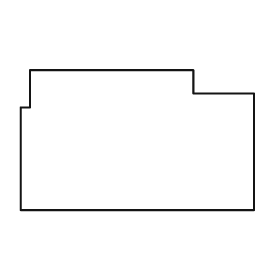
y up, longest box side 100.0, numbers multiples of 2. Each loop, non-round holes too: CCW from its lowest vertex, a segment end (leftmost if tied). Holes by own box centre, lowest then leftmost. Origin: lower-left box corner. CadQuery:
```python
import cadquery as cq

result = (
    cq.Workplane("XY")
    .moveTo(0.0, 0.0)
    .lineTo(100.0, 0.0)
    .lineTo(100.0, 50.0)
    .lineTo(74.0, 50.0)
    .lineTo(74.0, 60.0)
    .lineTo(4.0, 60.0)
    .lineTo(4.0, 44.0)
    .lineTo(0.0, 44.0)
    .close()
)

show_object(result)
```